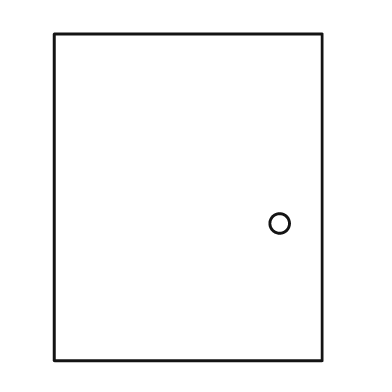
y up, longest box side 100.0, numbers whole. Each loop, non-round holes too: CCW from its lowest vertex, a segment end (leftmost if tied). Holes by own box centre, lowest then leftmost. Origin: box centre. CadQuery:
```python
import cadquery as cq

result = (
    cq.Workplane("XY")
    .moveTo(-41.0, -50.0)
    .lineTo(41.0, -50.0)
    .lineTo(41.0, 50.0)
    .lineTo(-41.0, 50.0)
    .close()
    .moveTo(28.0, -8.0)
    .circle(3.0)
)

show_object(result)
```